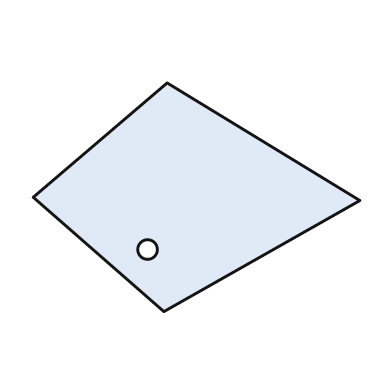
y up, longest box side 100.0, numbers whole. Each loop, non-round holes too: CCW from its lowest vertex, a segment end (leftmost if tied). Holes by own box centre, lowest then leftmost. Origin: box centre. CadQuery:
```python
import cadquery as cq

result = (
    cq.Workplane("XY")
    .moveTo(-10.0, -35.0)
    .lineTo(50.0, -1.0)
    .lineTo(-9.0, 35.0)
    .lineTo(-50.0, 0.0)
    .close()
    .moveTo(-15.0, -16.0)
    .circle(3.0)
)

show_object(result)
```